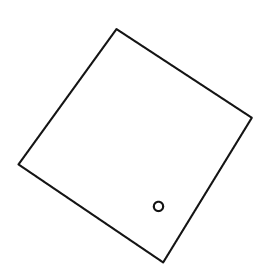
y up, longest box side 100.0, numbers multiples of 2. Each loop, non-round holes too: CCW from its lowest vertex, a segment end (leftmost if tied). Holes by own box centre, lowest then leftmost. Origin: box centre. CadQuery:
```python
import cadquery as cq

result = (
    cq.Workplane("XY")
    .moveTo(12.0, -50.0)
    .lineTo(50.0, 12.0)
    .lineTo(-8.0, 50.0)
    .lineTo(-50.0, -8.0)
    .close()
    .moveTo(10.0, -26.0)
    .circle(2.0)
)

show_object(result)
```